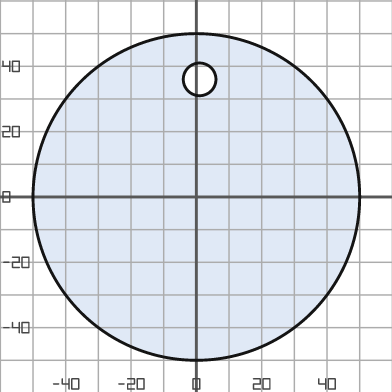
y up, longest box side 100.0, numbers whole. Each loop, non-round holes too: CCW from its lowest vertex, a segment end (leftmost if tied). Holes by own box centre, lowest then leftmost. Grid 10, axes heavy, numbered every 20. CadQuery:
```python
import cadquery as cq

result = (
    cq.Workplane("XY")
    .moveTo(0.0, 0.0)
    .circle(50.0)
    .moveTo(1.0, 36.0)
    .circle(5.0)
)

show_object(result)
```